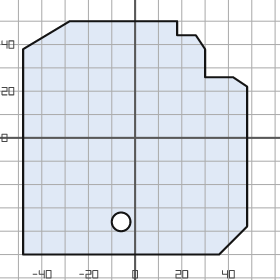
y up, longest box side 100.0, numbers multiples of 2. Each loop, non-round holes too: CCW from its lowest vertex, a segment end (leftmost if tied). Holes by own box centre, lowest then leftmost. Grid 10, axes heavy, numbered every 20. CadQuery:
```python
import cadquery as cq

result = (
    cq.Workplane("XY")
    .moveTo(-48.0, -50.0)
    .lineTo(36.0, -50.0)
    .lineTo(48.0, -38.0)
    .lineTo(48.0, 22.0)
    .lineTo(42.0, 26.0)
    .lineTo(30.0, 26.0)
    .lineTo(30.0, 38.0)
    .lineTo(26.0, 44.0)
    .lineTo(18.0, 44.0)
    .lineTo(18.0, 50.0)
    .lineTo(-28.0, 50.0)
    .lineTo(-48.0, 38.0)
    .close()
    .moveTo(-6.0, -36.0)
    .circle(4.0)
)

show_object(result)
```